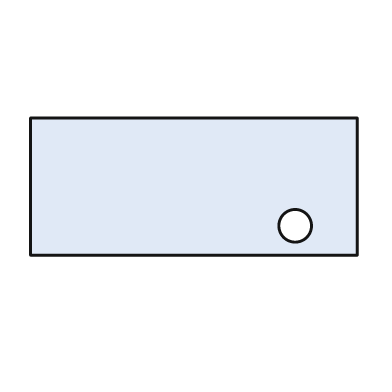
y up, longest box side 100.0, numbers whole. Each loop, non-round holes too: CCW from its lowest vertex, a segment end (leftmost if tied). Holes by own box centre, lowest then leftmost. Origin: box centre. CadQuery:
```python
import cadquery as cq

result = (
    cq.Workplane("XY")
    .moveTo(-50.0, -21.0)
    .lineTo(50.0, -21.0)
    .lineTo(50.0, 21.0)
    .lineTo(-50.0, 21.0)
    .close()
    .moveTo(31.0, -12.0)
    .circle(5.0)
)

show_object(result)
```